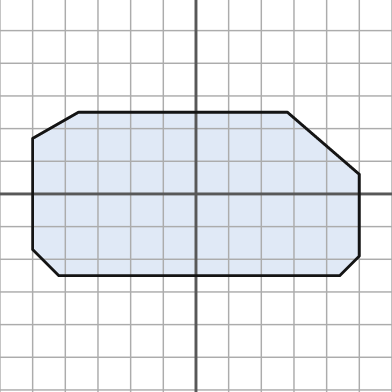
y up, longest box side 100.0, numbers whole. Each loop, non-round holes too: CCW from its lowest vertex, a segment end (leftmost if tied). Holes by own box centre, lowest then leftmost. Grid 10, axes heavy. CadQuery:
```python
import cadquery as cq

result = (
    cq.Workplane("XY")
    .moveTo(-42.0, -25.0)
    .lineTo(44.0, -25.0)
    .lineTo(50.0, -19.0)
    .lineTo(50.0, 6.0)
    .lineTo(28.0, 25.0)
    .lineTo(-36.0, 25.0)
    .lineTo(-50.0, 17.0)
    .lineTo(-50.0, -17.0)
    .close()
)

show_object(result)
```